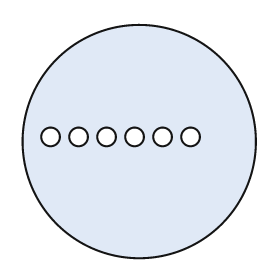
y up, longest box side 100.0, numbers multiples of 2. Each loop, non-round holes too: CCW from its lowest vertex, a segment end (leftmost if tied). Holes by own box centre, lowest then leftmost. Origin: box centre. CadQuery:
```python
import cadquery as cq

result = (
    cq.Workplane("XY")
    .moveTo(0.0, 0.0)
    .circle(50.0)
    .moveTo(-38.0, 2.0)
    .circle(4.0)
    .moveTo(-26.0, 2.0)
    .circle(4.0)
    .moveTo(-14.0, 2.0)
    .circle(4.0)
    .moveTo(-2.0, 2.0)
    .circle(4.0)
    .moveTo(10.0, 2.0)
    .circle(4.0)
    .moveTo(22.0, 2.0)
    .circle(4.0)
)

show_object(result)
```